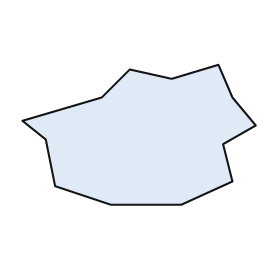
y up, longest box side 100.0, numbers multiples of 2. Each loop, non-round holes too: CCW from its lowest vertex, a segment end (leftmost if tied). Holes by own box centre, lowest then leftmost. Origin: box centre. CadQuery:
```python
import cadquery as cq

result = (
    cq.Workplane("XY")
    .moveTo(-12.0, -30.0)
    .lineTo(18.0, -30.0)
    .lineTo(40.0, -20.0)
    .lineTo(36.0, -4.0)
    .lineTo(50.0, 4.0)
    .lineTo(40.0, 16.0)
    .lineTo(34.0, 30.0)
    .lineTo(14.0, 24.0)
    .lineTo(-4.0, 28.0)
    .lineTo(-16.0, 16.0)
    .lineTo(-50.0, 6.0)
    .lineTo(-40.0, -2.0)
    .lineTo(-36.0, -22.0)
    .close()
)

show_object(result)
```